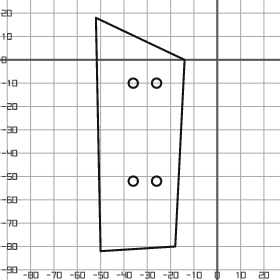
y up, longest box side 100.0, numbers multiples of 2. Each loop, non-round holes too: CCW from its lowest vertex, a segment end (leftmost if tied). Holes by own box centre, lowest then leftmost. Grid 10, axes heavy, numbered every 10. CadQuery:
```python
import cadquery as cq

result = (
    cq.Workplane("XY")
    .moveTo(-50.0, -82.0)
    .lineTo(-18.0, -80.0)
    .lineTo(-14.0, 0.0)
    .lineTo(-52.0, 18.0)
    .close()
    .moveTo(-36.0, -52.0)
    .circle(2.0)
    .moveTo(-26.0, -52.0)
    .circle(2.0)
    .moveTo(-36.0, -10.0)
    .circle(2.0)
    .moveTo(-26.0, -10.0)
    .circle(2.0)
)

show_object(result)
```